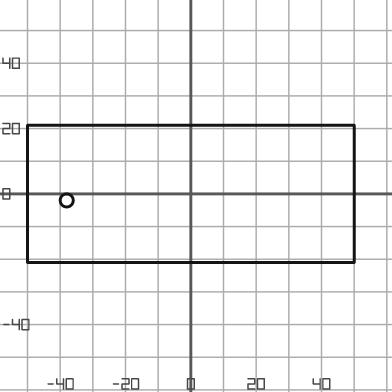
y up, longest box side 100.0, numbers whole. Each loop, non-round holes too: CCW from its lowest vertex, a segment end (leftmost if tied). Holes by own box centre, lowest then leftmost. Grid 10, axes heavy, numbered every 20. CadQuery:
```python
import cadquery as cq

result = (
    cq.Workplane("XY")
    .moveTo(-50.0, -21.0)
    .lineTo(50.0, -21.0)
    .lineTo(50.0, 21.0)
    .lineTo(-50.0, 21.0)
    .close()
    .moveTo(-38.0, -2.0)
    .circle(2.0)
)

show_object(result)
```